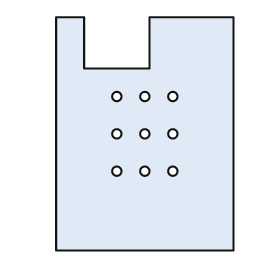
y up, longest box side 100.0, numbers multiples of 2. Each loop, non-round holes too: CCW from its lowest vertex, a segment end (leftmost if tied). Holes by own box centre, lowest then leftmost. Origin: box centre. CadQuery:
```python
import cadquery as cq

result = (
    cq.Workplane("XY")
    .moveTo(-38.0, -50.0)
    .lineTo(38.0, -50.0)
    .lineTo(38.0, 50.0)
    .lineTo(2.0, 50.0)
    .lineTo(2.0, 28.0)
    .lineTo(-26.0, 28.0)
    .lineTo(-26.0, 50.0)
    .lineTo(-38.0, 50.0)
    .close()
    .moveTo(-12.0, -16.0)
    .circle(2.0)
    .moveTo(0.0, -16.0)
    .circle(2.0)
    .moveTo(12.0, -16.0)
    .circle(2.0)
    .moveTo(-12.0, 0.0)
    .circle(2.0)
    .moveTo(0.0, 0.0)
    .circle(2.0)
    .moveTo(12.0, 0.0)
    .circle(2.0)
    .moveTo(-12.0, 16.0)
    .circle(2.0)
    .moveTo(0.0, 16.0)
    .circle(2.0)
    .moveTo(12.0, 16.0)
    .circle(2.0)
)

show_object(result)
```